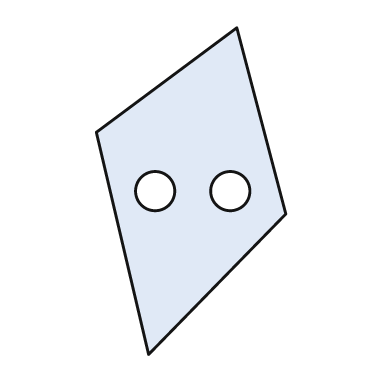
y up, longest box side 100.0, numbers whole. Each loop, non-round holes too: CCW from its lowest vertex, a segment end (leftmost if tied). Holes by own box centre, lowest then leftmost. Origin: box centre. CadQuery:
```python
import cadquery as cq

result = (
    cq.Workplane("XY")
    .moveTo(-13.0, -50.0)
    .lineTo(29.0, -7.0)
    .lineTo(14.0, 50.0)
    .lineTo(-29.0, 18.0)
    .close()
    .moveTo(-11.0, 0.0)
    .circle(6.0)
    .moveTo(12.0, 0.0)
    .circle(6.0)
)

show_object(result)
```